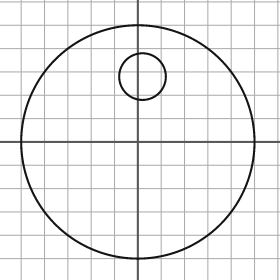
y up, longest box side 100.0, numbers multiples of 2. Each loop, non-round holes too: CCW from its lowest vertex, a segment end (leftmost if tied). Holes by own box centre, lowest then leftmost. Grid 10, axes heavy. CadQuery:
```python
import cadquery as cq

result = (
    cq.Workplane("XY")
    .moveTo(0.0, 0.0)
    .circle(50.0)
    .moveTo(2.0, 28.0)
    .circle(10.0)
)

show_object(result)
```